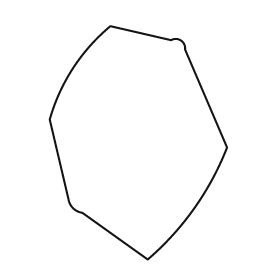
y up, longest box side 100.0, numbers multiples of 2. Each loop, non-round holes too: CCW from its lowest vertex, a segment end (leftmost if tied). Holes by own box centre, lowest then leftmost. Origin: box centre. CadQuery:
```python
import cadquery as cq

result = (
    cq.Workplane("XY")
    .moveTo(4.0, -50.0)
    .threePointArc((24.0, -28.0), (38.0, -2.0))
    .lineTo(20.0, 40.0)
    .threePointArc((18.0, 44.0), (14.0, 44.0))
    .lineTo(-12.0, 50.0)
    .threePointArc((-28.0, 32.0), (-38.0, 10.0))
    .lineTo(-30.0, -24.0)
    .threePointArc((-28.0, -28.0), (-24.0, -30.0))
    .close()
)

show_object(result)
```